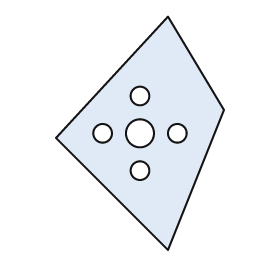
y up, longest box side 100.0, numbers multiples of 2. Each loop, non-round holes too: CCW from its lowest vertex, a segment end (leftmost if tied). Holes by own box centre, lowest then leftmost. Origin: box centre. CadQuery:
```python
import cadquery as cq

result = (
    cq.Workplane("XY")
    .moveTo(12.0, -50.0)
    .lineTo(36.0, 10.0)
    .lineTo(12.0, 50.0)
    .lineTo(-36.0, -2.0)
    .close()
    .moveTo(0.0, -16.0)
    .circle(4.0)
    .moveTo(-16.0, 0.0)
    .circle(4.0)
    .moveTo(0.0, 0.0)
    .circle(6.0)
    .moveTo(16.0, 0.0)
    .circle(4.0)
    .moveTo(0.0, 16.0)
    .circle(4.0)
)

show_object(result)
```